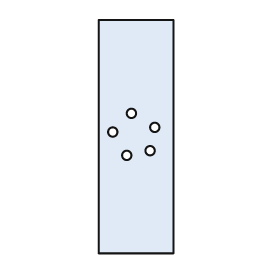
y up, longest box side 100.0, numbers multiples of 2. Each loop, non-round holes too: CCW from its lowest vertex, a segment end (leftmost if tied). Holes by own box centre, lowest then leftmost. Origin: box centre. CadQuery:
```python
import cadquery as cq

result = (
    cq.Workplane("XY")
    .moveTo(-16.0, -50.0)
    .lineTo(16.0, -50.0)
    .lineTo(16.0, 50.0)
    .lineTo(-16.0, 50.0)
    .close()
    .moveTo(-4.0, -8.0)
    .circle(2.0)
    .moveTo(6.0, -6.0)
    .circle(2.0)
    .moveTo(-10.0, 2.0)
    .circle(2.0)
    .moveTo(8.0, 4.0)
    .circle(2.0)
    .moveTo(-2.0, 10.0)
    .circle(2.0)
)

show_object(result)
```